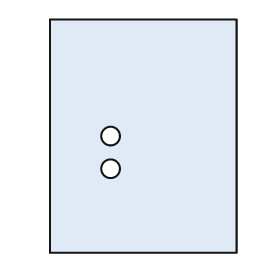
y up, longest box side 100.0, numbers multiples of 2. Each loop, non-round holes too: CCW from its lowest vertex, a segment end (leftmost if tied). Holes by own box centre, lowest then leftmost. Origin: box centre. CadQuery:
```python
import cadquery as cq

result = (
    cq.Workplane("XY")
    .moveTo(-40.0, -50.0)
    .lineTo(40.0, -50.0)
    .lineTo(40.0, 50.0)
    .lineTo(-40.0, 50.0)
    .close()
    .moveTo(-14.0, -14.0)
    .circle(4.0)
    .moveTo(-14.0, 0.0)
    .circle(4.0)
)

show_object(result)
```